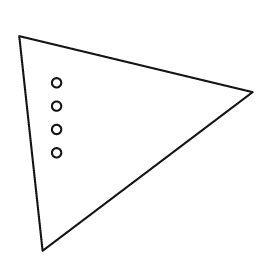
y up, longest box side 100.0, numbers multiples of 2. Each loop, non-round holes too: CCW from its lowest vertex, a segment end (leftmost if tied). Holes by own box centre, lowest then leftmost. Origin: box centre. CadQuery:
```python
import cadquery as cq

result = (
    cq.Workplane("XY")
    .moveTo(-40.0, -46.0)
    .lineTo(50.0, 22.0)
    .lineTo(-50.0, 46.0)
    .close()
    .moveTo(-34.0, -4.0)
    .circle(2.0)
    .moveTo(-34.0, 6.0)
    .circle(2.0)
    .moveTo(-34.0, 16.0)
    .circle(2.0)
    .moveTo(-34.0, 26.0)
    .circle(2.0)
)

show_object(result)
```